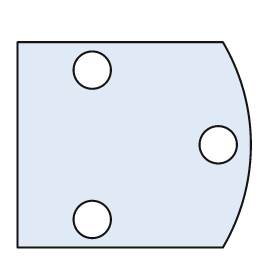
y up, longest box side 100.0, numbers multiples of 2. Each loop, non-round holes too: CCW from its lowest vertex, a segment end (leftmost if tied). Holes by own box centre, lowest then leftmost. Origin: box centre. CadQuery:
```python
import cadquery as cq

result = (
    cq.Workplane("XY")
    .moveTo(-50.0, -44.0)
    .lineTo(38.0, -44.0)
    .threePointArc((50.0, 0.0), (38.0, 44.0))
    .lineTo(-50.0, 44.0)
    .close()
    .moveTo(-18.0, -32.0)
    .circle(8.0)
    .moveTo(36.0, 0.0)
    .circle(8.0)
    .moveTo(-18.0, 32.0)
    .circle(8.0)
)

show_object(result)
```